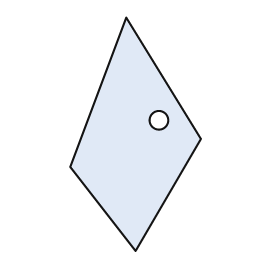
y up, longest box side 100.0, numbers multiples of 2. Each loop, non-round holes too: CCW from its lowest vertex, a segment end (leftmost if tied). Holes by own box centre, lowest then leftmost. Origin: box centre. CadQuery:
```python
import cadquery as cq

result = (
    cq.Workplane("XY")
    .moveTo(0.0, -50.0)
    .lineTo(28.0, -2.0)
    .lineTo(-4.0, 50.0)
    .lineTo(-28.0, -14.0)
    .close()
    .moveTo(10.0, 6.0)
    .circle(4.0)
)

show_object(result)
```